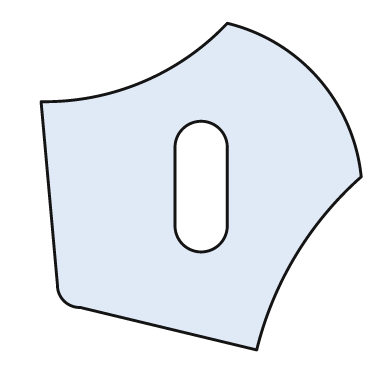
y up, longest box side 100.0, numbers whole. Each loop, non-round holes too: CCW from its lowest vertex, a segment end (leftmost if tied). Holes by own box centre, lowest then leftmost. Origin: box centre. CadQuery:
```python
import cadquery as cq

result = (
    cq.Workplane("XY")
    .moveTo(17.0, -50.0)
    .threePointArc((29.0, -21.0), (49.0, 3.0))
    .threePointArc((36.0, 33.0), (8.0, 50.0))
    .threePointArc((-18.0, 32.0), (-49.0, 26.0))
    .lineTo(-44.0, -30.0)
    .threePointArc((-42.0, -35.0), (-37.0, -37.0))
    .close()
    .moveTo(-8.0, -12.0)
    .threePointArc((0.0, -20.0), (8.0, -12.0))
    .lineTo(8.0, 12.0)
    .threePointArc((0.0, 20.0), (-8.0, 12.0))
    .close()
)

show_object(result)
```